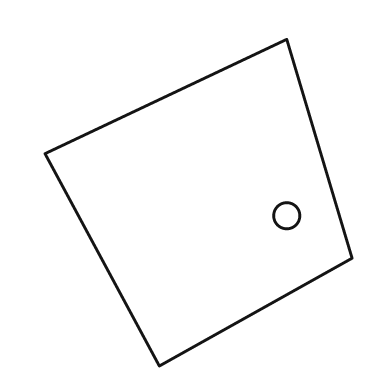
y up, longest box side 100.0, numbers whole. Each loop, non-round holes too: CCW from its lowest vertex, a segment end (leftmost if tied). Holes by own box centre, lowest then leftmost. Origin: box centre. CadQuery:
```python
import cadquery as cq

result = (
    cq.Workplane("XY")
    .moveTo(-12.0, -50.0)
    .lineTo(47.0, -17.0)
    .lineTo(27.0, 50.0)
    .lineTo(-47.0, 15.0)
    .close()
    .moveTo(27.0, -4.0)
    .circle(4.0)
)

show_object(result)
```